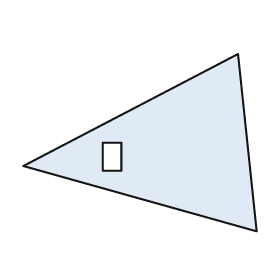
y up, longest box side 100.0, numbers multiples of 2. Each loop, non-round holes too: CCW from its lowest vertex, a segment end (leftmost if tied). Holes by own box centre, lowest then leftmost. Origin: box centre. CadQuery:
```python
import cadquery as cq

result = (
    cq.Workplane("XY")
    .moveTo(50.0, -38.0)
    .lineTo(42.0, 38.0)
    .lineTo(-50.0, -10.0)
    .close()
    .moveTo(-16.0, -12.0)
    .lineTo(-8.0, -12.0)
    .lineTo(-8.0, 0.0)
    .lineTo(-16.0, 0.0)
    .close()
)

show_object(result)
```